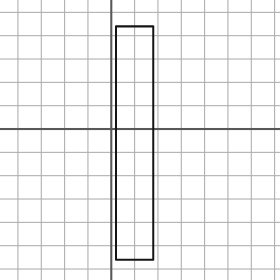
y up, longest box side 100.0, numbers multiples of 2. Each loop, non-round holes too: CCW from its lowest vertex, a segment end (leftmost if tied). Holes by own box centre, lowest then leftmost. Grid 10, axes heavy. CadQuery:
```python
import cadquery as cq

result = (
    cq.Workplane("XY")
    .moveTo(2.0, -56.0)
    .lineTo(18.0, -56.0)
    .lineTo(18.0, 44.0)
    .lineTo(2.0, 44.0)
    .close()
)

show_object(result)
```